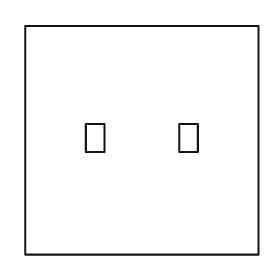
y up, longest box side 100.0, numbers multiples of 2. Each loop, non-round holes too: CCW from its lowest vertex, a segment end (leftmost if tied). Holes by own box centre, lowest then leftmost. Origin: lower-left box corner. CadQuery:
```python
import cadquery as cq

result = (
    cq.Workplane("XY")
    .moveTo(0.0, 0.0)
    .lineTo(100.0, 0.0)
    .lineTo(100.0, 98.0)
    .lineTo(0.0, 98.0)
    .close()
    .moveTo(26.0, 44.0)
    .lineTo(34.0, 44.0)
    .lineTo(34.0, 56.0)
    .lineTo(26.0, 56.0)
    .close()
    .moveTo(66.0, 44.0)
    .lineTo(74.0, 44.0)
    .lineTo(74.0, 56.0)
    .lineTo(66.0, 56.0)
    .close()
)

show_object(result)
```